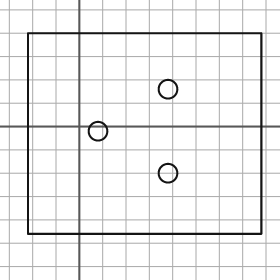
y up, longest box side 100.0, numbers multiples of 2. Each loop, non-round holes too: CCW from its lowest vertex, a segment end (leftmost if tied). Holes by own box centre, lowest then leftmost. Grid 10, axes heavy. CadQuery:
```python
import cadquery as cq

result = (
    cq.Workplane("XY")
    .moveTo(-22.0, -46.0)
    .lineTo(78.0, -46.0)
    .lineTo(78.0, 40.0)
    .lineTo(-22.0, 40.0)
    .close()
    .moveTo(38.0, -20.0)
    .circle(4.0)
    .moveTo(8.0, -2.0)
    .circle(4.0)
    .moveTo(38.0, 16.0)
    .circle(4.0)
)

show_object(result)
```